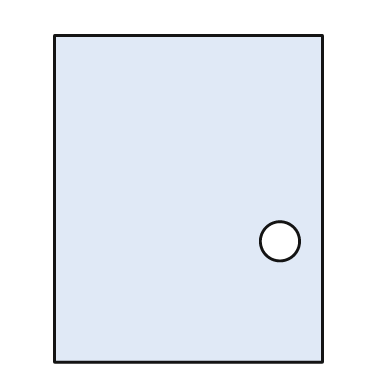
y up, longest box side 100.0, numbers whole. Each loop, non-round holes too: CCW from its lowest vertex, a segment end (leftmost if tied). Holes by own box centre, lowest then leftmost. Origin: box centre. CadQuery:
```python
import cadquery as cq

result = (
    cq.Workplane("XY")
    .moveTo(-41.0, -50.0)
    .lineTo(41.0, -50.0)
    .lineTo(41.0, 50.0)
    .lineTo(-41.0, 50.0)
    .close()
    .moveTo(28.0, -13.0)
    .circle(6.0)
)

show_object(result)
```